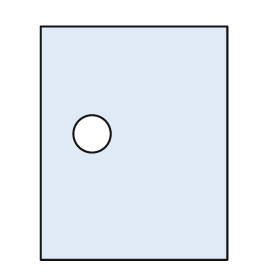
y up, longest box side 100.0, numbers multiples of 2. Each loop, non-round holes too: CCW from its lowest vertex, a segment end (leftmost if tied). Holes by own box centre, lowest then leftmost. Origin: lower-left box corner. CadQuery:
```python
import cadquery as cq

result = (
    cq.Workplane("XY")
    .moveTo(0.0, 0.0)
    .lineTo(80.0, 0.0)
    .lineTo(80.0, 100.0)
    .lineTo(0.0, 100.0)
    .close()
    .moveTo(22.0, 54.0)
    .circle(8.0)
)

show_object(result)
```